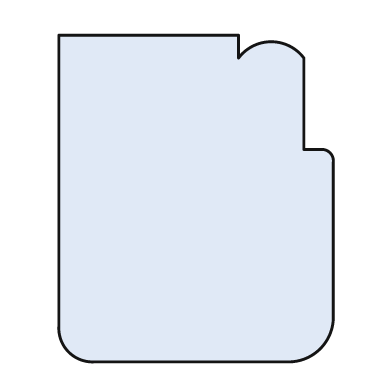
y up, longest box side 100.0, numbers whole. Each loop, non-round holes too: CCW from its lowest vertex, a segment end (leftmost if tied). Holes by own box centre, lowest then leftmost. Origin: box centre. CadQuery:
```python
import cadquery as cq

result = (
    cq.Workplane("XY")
    .moveTo(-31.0, -50.0)
    .lineTo(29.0, -50.0)
    .threePointArc((38.0, -46.0), (42.0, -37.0))
    .lineTo(42.0, 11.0)
    .threePointArc((41.0, 14.0), (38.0, 15.0))
    .lineTo(33.0, 15.0)
    .lineTo(33.0, 43.0)
    .threePointArc((23.0, 48.0), (13.0, 43.0))
    .lineTo(13.0, 50.0)
    .lineTo(-42.0, 50.0)
    .lineTo(-42.0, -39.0)
    .threePointArc((-39.0, -47.0), (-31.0, -50.0))
    .close()
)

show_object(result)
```